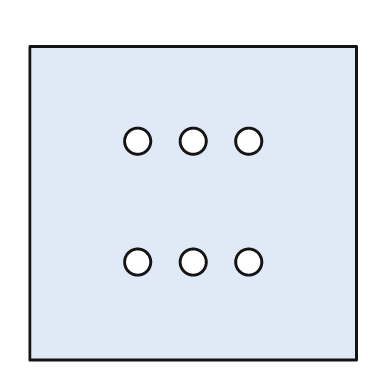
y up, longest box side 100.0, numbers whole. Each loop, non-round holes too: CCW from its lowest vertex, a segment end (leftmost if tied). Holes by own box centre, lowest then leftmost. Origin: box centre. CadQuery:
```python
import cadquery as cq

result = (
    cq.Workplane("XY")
    .moveTo(-50.0, -48.0)
    .lineTo(50.0, -48.0)
    .lineTo(50.0, 48.0)
    .lineTo(-50.0, 48.0)
    .close()
    .moveTo(-17.0, -18.0)
    .circle(4.0)
    .moveTo(0.0, -18.0)
    .circle(4.0)
    .moveTo(17.0, -18.0)
    .circle(4.0)
    .moveTo(-17.0, 19.0)
    .circle(4.0)
    .moveTo(0.0, 19.0)
    .circle(4.0)
    .moveTo(17.0, 19.0)
    .circle(4.0)
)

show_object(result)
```